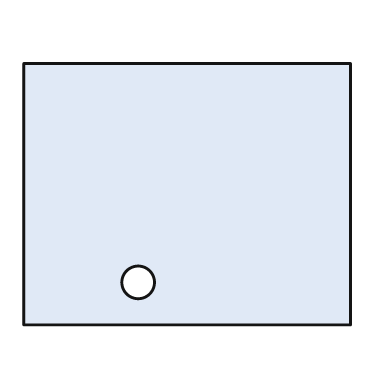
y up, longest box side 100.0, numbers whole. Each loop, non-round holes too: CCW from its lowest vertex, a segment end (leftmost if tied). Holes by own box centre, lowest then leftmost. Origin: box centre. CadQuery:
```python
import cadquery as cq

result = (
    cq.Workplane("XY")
    .moveTo(-50.0, -40.0)
    .lineTo(50.0, -40.0)
    .lineTo(50.0, 40.0)
    .lineTo(-50.0, 40.0)
    .close()
    .moveTo(-15.0, -27.0)
    .circle(5.0)
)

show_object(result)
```